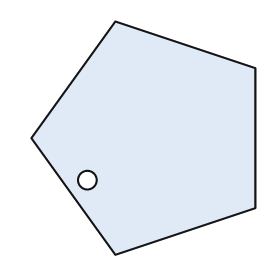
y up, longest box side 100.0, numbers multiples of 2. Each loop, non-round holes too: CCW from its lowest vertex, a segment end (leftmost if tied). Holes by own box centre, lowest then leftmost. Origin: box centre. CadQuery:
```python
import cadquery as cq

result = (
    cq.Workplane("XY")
    .moveTo(-12.0, -50.0)
    .lineTo(48.0, -30.0)
    .lineTo(48.0, 30.0)
    .lineTo(-12.0, 50.0)
    .lineTo(-48.0, 0.0)
    .close()
    .moveTo(-24.0, -18.0)
    .circle(4.0)
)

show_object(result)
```